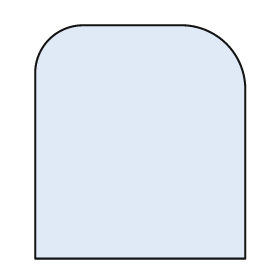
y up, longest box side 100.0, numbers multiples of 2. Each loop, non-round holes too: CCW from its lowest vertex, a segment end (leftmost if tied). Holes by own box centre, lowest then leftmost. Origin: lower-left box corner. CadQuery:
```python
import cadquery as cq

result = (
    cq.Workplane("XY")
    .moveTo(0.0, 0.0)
    .lineTo(90.0, 0.0)
    .lineTo(90.0, 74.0)
    .threePointArc((82.0, 92.0), (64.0, 100.0))
    .lineTo(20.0, 100.0)
    .threePointArc((6.0, 94.0), (0.0, 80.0))
    .close()
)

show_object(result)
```